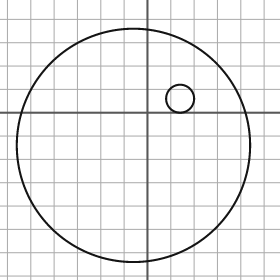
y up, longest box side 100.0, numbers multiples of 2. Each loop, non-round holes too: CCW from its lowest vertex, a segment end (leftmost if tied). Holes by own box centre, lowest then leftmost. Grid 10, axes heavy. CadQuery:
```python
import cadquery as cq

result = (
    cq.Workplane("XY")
    .moveTo(-6.0, -14.0)
    .circle(50.0)
    .moveTo(14.0, 6.0)
    .circle(6.0)
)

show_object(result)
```